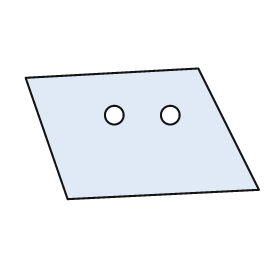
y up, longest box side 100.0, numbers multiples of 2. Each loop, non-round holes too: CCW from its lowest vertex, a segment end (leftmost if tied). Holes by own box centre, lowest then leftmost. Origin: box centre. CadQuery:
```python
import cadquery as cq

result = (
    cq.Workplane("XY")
    .moveTo(-32.0, -28.0)
    .lineTo(50.0, -24.0)
    .lineTo(24.0, 28.0)
    .lineTo(-50.0, 24.0)
    .close()
    .moveTo(-12.0, 8.0)
    .circle(4.0)
    .moveTo(12.0, 8.0)
    .circle(4.0)
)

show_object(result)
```